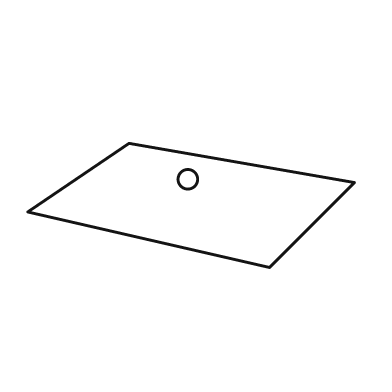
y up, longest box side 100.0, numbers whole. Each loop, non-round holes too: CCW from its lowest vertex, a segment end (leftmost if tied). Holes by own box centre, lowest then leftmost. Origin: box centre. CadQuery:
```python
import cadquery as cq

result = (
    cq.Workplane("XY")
    .moveTo(24.0, -19.0)
    .lineTo(50.0, 7.0)
    .lineTo(-19.0, 19.0)
    .lineTo(-50.0, -2.0)
    .close()
    .moveTo(-1.0, 8.0)
    .circle(3.0)
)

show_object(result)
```